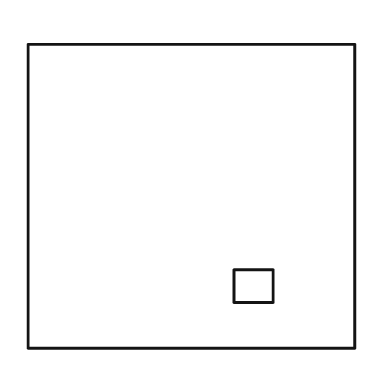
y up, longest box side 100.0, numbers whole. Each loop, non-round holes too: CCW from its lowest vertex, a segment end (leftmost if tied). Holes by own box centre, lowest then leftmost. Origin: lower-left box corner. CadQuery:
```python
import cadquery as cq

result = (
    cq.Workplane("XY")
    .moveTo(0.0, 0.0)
    .lineTo(100.0, 0.0)
    .lineTo(100.0, 93.0)
    .lineTo(0.0, 93.0)
    .close()
    .moveTo(63.0, 14.0)
    .lineTo(75.0, 14.0)
    .lineTo(75.0, 24.0)
    .lineTo(63.0, 24.0)
    .close()
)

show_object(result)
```